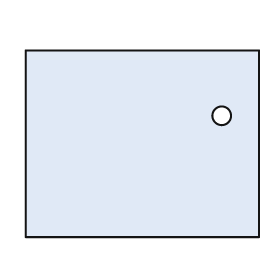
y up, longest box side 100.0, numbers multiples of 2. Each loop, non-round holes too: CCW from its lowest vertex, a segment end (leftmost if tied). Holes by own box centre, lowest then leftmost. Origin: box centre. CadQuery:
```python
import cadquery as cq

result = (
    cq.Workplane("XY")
    .moveTo(-50.0, -40.0)
    .lineTo(50.0, -40.0)
    .lineTo(50.0, 40.0)
    .lineTo(-50.0, 40.0)
    .close()
    .moveTo(34.0, 12.0)
    .circle(4.0)
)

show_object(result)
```